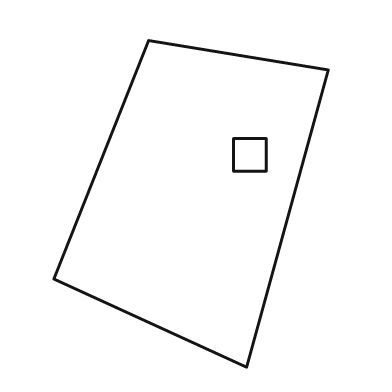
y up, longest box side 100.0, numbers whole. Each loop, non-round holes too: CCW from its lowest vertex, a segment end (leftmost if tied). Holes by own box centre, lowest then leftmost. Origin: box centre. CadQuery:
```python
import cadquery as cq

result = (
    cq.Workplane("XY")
    .moveTo(17.0, -50.0)
    .lineTo(42.0, 41.0)
    .lineTo(-13.0, 50.0)
    .lineTo(-42.0, -23.0)
    .close()
    .moveTo(13.0, 10.0)
    .lineTo(23.0, 10.0)
    .lineTo(23.0, 20.0)
    .lineTo(13.0, 20.0)
    .close()
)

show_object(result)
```